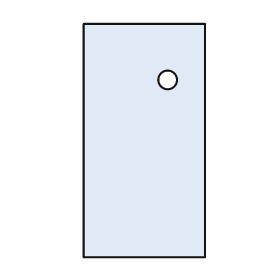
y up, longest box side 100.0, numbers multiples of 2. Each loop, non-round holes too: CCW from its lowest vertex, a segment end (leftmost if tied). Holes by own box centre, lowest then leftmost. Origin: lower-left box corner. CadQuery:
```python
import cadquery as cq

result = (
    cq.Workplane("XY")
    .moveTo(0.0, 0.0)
    .lineTo(52.0, 0.0)
    .lineTo(52.0, 100.0)
    .lineTo(0.0, 100.0)
    .close()
    .moveTo(36.0, 76.0)
    .circle(4.0)
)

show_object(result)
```